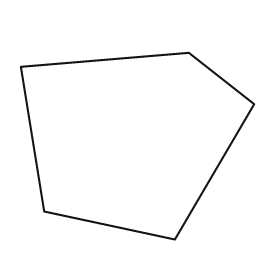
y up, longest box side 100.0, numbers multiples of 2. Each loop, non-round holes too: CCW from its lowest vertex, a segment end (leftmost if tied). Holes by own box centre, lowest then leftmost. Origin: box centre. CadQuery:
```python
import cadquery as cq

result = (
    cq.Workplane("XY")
    .moveTo(16.0, -40.0)
    .lineTo(50.0, 18.0)
    .lineTo(22.0, 40.0)
    .lineTo(-50.0, 34.0)
    .lineTo(-40.0, -28.0)
    .close()
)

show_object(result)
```